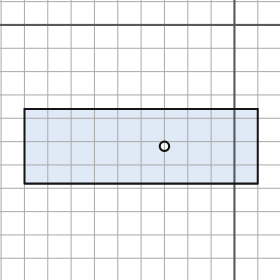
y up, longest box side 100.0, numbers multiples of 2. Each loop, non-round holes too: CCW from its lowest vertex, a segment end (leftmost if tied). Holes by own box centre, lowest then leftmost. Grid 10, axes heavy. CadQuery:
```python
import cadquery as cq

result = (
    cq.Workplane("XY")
    .moveTo(-90.0, -68.0)
    .lineTo(10.0, -68.0)
    .lineTo(10.0, -36.0)
    .lineTo(-90.0, -36.0)
    .close()
    .moveTo(-30.0, -52.0)
    .circle(2.0)
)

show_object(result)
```